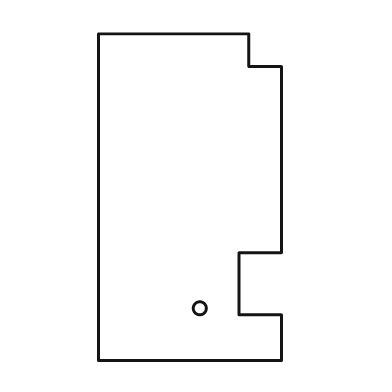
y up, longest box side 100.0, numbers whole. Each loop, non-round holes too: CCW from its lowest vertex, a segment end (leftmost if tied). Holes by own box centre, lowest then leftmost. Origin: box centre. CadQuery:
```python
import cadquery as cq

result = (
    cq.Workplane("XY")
    .moveTo(-28.0, -50.0)
    .lineTo(28.0, -50.0)
    .lineTo(28.0, -36.0)
    .lineTo(15.0, -36.0)
    .lineTo(15.0, -17.0)
    .lineTo(28.0, -17.0)
    .lineTo(28.0, 40.0)
    .lineTo(18.0, 40.0)
    .lineTo(18.0, 50.0)
    .lineTo(-28.0, 50.0)
    .close()
    .moveTo(3.0, -34.0)
    .circle(2.0)
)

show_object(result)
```